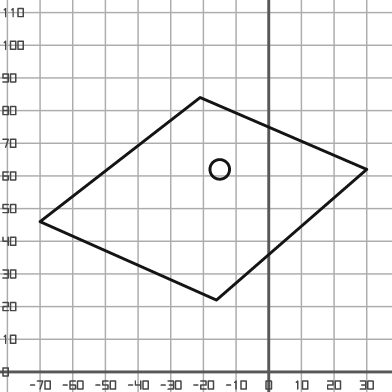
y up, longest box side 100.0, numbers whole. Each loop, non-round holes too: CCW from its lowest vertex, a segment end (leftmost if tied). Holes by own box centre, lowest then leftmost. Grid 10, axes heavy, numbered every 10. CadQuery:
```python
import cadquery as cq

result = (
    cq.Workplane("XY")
    .moveTo(-16.0, 22.0)
    .lineTo(30.0, 62.0)
    .lineTo(-21.0, 84.0)
    .lineTo(-70.0, 46.0)
    .close()
    .moveTo(-15.0, 62.0)
    .circle(3.0)
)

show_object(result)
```